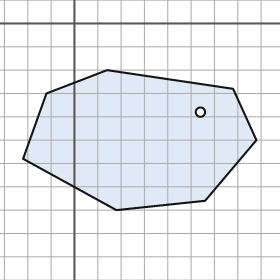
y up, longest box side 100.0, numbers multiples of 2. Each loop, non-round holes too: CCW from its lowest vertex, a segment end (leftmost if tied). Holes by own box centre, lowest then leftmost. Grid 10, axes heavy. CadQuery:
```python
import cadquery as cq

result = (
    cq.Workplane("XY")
    .moveTo(18.0, -80.0)
    .lineTo(56.0, -76.0)
    .lineTo(78.0, -50.0)
    .lineTo(68.0, -28.0)
    .lineTo(14.0, -20.0)
    .lineTo(-12.0, -30.0)
    .lineTo(-22.0, -58.0)
    .close()
    .moveTo(54.0, -38.0)
    .circle(2.0)
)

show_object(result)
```